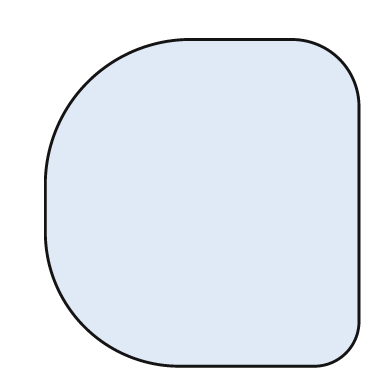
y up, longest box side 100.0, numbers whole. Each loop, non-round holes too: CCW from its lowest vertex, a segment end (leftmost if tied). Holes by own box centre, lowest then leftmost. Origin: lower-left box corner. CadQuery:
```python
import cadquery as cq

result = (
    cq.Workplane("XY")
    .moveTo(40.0, 0.0)
    .lineTo(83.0, 0.0)
    .threePointArc((92.0, 4.0), (96.0, 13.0))
    .lineTo(96.0, 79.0)
    .threePointArc((90.0, 94.0), (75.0, 100.0))
    .lineTo(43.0, 100.0)
    .threePointArc((13.0, 87.0), (0.0, 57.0))
    .lineTo(0.0, 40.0)
    .threePointArc((12.0, 12.0), (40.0, 0.0))
    .close()
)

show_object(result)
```